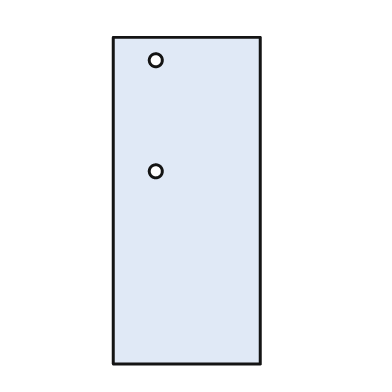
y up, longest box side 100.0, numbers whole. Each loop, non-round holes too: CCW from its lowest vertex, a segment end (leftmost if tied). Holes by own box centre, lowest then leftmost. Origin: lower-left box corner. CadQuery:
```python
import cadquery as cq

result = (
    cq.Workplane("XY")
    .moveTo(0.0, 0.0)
    .lineTo(45.0, 0.0)
    .lineTo(45.0, 100.0)
    .lineTo(0.0, 100.0)
    .close()
    .moveTo(13.0, 59.0)
    .circle(2.0)
    .moveTo(13.0, 93.0)
    .circle(2.0)
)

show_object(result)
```